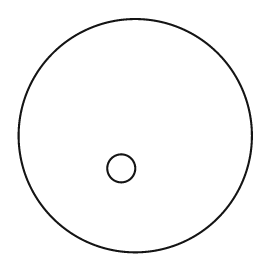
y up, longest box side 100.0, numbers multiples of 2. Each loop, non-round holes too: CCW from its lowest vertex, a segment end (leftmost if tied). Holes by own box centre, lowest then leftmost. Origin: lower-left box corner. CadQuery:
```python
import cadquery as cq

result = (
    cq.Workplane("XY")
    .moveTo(50.0, 50.0)
    .circle(50.0)
    .moveTo(44.0, 36.0)
    .circle(6.0)
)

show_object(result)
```